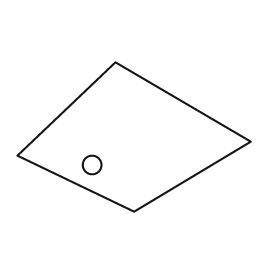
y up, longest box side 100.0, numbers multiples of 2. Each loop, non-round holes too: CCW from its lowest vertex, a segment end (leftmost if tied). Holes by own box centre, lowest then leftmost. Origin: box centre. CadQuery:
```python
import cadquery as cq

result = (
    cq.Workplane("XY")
    .moveTo(0.0, -32.0)
    .lineTo(50.0, -2.0)
    .lineTo(-8.0, 32.0)
    .lineTo(-50.0, -8.0)
    .close()
    .moveTo(-18.0, -12.0)
    .circle(4.0)
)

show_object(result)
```